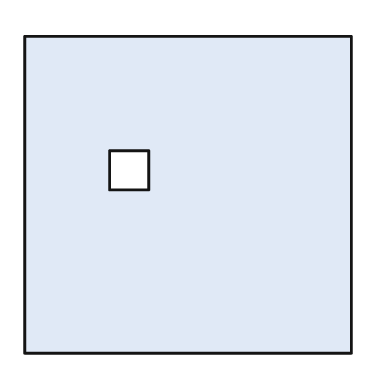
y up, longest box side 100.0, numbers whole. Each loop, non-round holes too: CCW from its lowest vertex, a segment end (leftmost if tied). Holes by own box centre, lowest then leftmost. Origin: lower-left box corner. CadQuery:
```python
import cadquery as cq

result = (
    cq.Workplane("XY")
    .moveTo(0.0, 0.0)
    .lineTo(100.0, 0.0)
    .lineTo(100.0, 97.0)
    .lineTo(0.0, 97.0)
    .close()
    .moveTo(26.0, 50.0)
    .lineTo(38.0, 50.0)
    .lineTo(38.0, 62.0)
    .lineTo(26.0, 62.0)
    .close()
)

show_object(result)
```